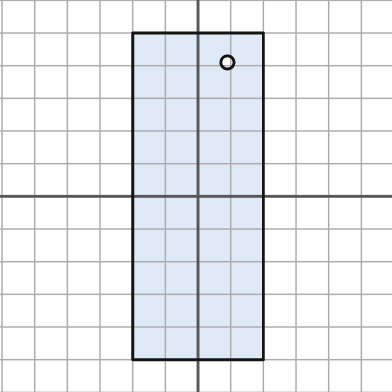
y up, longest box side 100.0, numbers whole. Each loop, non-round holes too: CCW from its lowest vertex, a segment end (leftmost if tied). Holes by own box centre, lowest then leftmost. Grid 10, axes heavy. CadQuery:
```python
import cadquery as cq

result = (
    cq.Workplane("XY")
    .moveTo(-20.0, -50.0)
    .lineTo(20.0, -50.0)
    .lineTo(20.0, 50.0)
    .lineTo(-20.0, 50.0)
    .close()
    .moveTo(9.0, 41.0)
    .circle(2.0)
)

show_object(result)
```